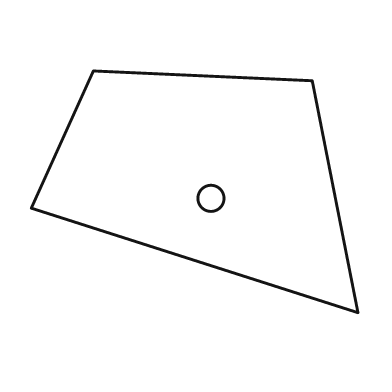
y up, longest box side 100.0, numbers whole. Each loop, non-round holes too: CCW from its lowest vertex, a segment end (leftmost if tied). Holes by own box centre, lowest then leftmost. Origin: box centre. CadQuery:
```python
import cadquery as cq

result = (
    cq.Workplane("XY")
    .moveTo(50.0, -37.0)
    .lineTo(36.0, 34.0)
    .lineTo(-31.0, 37.0)
    .lineTo(-50.0, -5.0)
    .close()
    .moveTo(5.0, -2.0)
    .circle(4.0)
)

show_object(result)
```